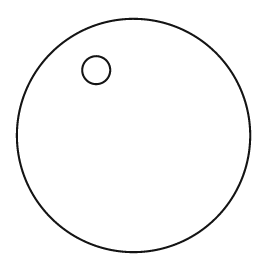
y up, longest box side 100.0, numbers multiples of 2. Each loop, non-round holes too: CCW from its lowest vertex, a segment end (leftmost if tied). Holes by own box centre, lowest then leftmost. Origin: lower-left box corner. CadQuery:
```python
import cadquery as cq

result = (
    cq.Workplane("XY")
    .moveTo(50.0, 50.0)
    .circle(50.0)
    .moveTo(34.0, 78.0)
    .circle(6.0)
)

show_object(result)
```